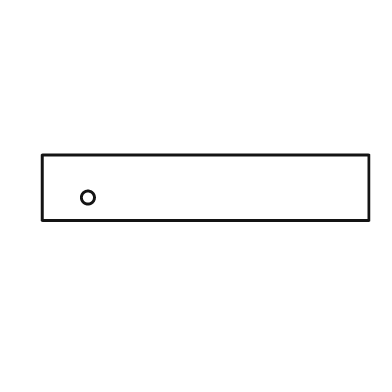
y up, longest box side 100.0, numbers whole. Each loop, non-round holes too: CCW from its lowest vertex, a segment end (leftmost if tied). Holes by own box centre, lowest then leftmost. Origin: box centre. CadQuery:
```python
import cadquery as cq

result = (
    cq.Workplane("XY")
    .moveTo(-50.0, -10.0)
    .lineTo(50.0, -10.0)
    .lineTo(50.0, 10.0)
    .lineTo(-50.0, 10.0)
    .close()
    .moveTo(-36.0, -3.0)
    .circle(2.0)
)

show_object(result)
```